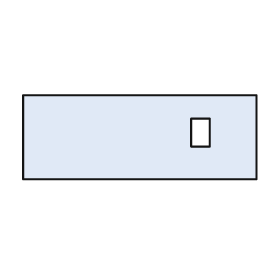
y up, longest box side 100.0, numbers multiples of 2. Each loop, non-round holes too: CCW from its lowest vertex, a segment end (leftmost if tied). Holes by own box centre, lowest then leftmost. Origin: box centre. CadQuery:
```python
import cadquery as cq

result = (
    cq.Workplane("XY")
    .moveTo(-50.0, -18.0)
    .lineTo(50.0, -18.0)
    .lineTo(50.0, 18.0)
    .lineTo(-50.0, 18.0)
    .close()
    .moveTo(22.0, -4.0)
    .lineTo(30.0, -4.0)
    .lineTo(30.0, 8.0)
    .lineTo(22.0, 8.0)
    .close()
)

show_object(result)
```